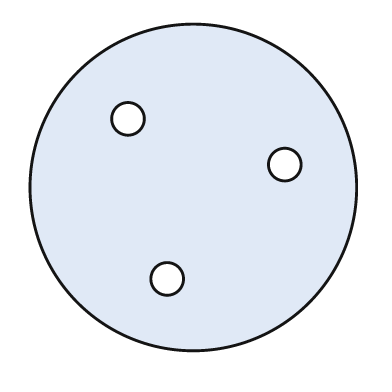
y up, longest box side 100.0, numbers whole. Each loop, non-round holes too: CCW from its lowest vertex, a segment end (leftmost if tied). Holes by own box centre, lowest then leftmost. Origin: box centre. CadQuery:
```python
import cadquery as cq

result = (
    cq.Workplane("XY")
    .moveTo(0.0, 0.0)
    .circle(50.0)
    .moveTo(-8.0, -28.0)
    .circle(5.0)
    .moveTo(28.0, 7.0)
    .circle(5.0)
    .moveTo(-20.0, 21.0)
    .circle(5.0)
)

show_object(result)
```